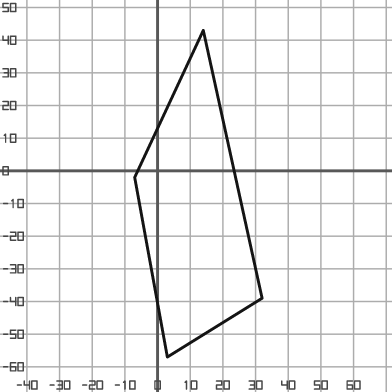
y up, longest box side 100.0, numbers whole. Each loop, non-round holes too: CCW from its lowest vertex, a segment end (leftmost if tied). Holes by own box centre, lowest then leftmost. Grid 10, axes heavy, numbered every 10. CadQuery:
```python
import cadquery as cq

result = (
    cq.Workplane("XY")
    .moveTo(3.0, -57.0)
    .lineTo(32.0, -39.0)
    .lineTo(14.0, 43.0)
    .lineTo(-7.0, -2.0)
    .close()
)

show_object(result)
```